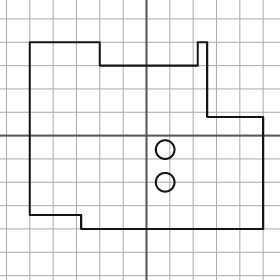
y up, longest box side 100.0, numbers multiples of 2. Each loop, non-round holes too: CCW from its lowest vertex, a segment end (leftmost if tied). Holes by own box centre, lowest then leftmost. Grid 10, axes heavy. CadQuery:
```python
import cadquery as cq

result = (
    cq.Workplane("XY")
    .moveTo(-28.0, -40.0)
    .lineTo(50.0, -40.0)
    .lineTo(50.0, 8.0)
    .lineTo(26.0, 8.0)
    .lineTo(26.0, 40.0)
    .lineTo(22.0, 40.0)
    .lineTo(22.0, 30.0)
    .lineTo(-20.0, 30.0)
    .lineTo(-20.0, 40.0)
    .lineTo(-50.0, 40.0)
    .lineTo(-50.0, -34.0)
    .lineTo(-28.0, -34.0)
    .close()
    .moveTo(8.0, -20.0)
    .circle(4.0)
    .moveTo(8.0, -6.0)
    .circle(4.0)
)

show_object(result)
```